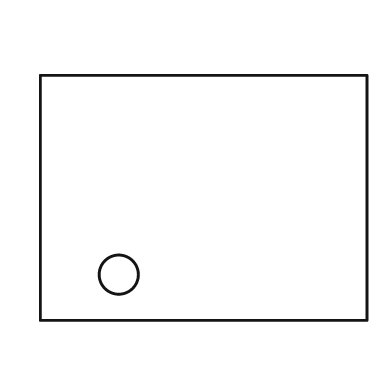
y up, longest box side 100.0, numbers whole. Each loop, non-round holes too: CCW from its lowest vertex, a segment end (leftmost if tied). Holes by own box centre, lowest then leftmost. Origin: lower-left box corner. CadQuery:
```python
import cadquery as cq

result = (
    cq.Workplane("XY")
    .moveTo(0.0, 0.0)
    .lineTo(100.0, 0.0)
    .lineTo(100.0, 75.0)
    .lineTo(0.0, 75.0)
    .close()
    .moveTo(24.0, 14.0)
    .circle(6.0)
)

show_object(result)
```